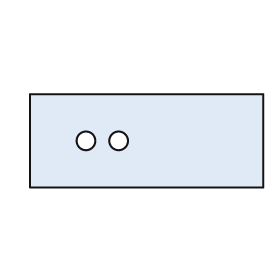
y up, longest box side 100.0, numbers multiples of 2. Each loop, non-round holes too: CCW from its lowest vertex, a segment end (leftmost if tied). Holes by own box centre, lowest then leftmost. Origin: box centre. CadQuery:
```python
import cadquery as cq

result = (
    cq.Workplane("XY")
    .moveTo(-50.0, -20.0)
    .lineTo(50.0, -20.0)
    .lineTo(50.0, 20.0)
    .lineTo(-50.0, 20.0)
    .close()
    .moveTo(-26.0, 0.0)
    .circle(4.0)
    .moveTo(-12.0, 0.0)
    .circle(4.0)
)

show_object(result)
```